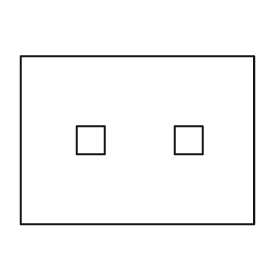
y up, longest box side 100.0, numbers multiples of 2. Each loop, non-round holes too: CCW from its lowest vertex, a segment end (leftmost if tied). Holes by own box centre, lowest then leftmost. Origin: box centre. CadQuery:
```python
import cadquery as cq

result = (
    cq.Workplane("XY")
    .moveTo(-50.0, -36.0)
    .lineTo(50.0, -36.0)
    .lineTo(50.0, 36.0)
    .lineTo(-50.0, 36.0)
    .close()
    .moveTo(-26.0, -6.0)
    .lineTo(-14.0, -6.0)
    .lineTo(-14.0, 6.0)
    .lineTo(-26.0, 6.0)
    .close()
    .moveTo(16.0, -6.0)
    .lineTo(28.0, -6.0)
    .lineTo(28.0, 6.0)
    .lineTo(16.0, 6.0)
    .close()
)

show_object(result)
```